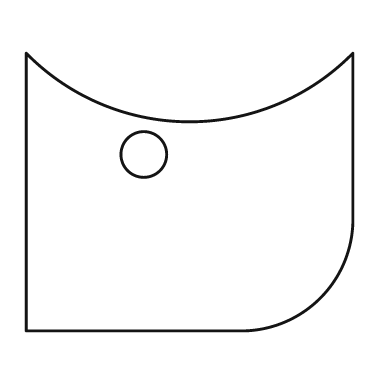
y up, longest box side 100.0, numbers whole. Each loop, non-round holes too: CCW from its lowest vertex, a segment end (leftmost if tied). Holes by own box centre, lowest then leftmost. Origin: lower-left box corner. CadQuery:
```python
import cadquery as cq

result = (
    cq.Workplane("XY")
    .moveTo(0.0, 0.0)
    .lineTo(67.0, 0.0)
    .threePointArc((90.0, 10.0), (100.0, 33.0))
    .lineTo(100.0, 85.0)
    .threePointArc((50.0, 64.0), (0.0, 85.0))
    .close()
    .moveTo(36.0, 54.0)
    .circle(7.0)
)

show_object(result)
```